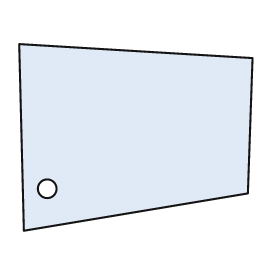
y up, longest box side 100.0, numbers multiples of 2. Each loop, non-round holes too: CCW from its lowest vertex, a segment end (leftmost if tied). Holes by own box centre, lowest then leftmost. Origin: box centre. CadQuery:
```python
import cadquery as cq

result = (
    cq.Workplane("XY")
    .moveTo(-48.0, -40.0)
    .lineTo(48.0, -24.0)
    .lineTo(50.0, 34.0)
    .lineTo(-50.0, 40.0)
    .close()
    .moveTo(-38.0, -22.0)
    .circle(4.0)
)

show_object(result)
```